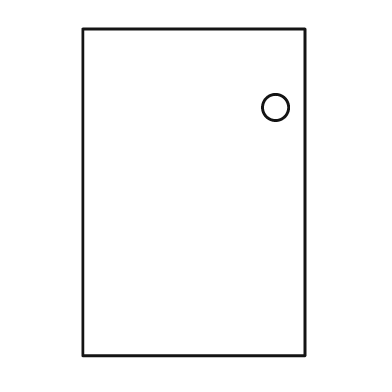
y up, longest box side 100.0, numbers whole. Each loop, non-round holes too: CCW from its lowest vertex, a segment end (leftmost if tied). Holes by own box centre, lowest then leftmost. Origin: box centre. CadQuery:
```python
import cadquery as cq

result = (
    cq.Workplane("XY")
    .moveTo(-34.0, -50.0)
    .lineTo(34.0, -50.0)
    .lineTo(34.0, 50.0)
    .lineTo(-34.0, 50.0)
    .close()
    .moveTo(25.0, 26.0)
    .circle(4.0)
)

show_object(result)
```